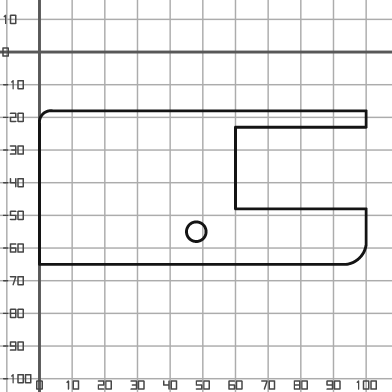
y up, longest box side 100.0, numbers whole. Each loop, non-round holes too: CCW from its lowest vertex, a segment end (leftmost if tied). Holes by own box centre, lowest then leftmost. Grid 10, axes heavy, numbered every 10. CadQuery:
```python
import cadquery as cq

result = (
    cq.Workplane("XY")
    .moveTo(0.0, -65.0)
    .lineTo(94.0, -65.0)
    .threePointArc((98.0, -63.0), (100.0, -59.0))
    .lineTo(100.0, -48.0)
    .lineTo(60.0, -48.0)
    .lineTo(60.0, -23.0)
    .lineTo(100.0, -23.0)
    .lineTo(100.0, -18.0)
    .lineTo(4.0, -18.0)
    .threePointArc((1.0, -19.0), (0.0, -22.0))
    .close()
    .moveTo(48.0, -55.0)
    .circle(3.0)
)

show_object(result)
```